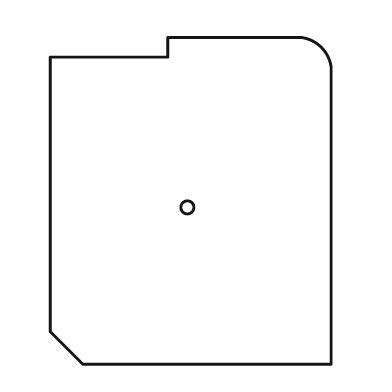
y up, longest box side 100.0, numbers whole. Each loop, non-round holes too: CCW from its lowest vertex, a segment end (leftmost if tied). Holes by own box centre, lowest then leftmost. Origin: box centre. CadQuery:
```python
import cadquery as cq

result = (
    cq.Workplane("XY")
    .moveTo(-33.0, -50.0)
    .lineTo(43.0, -50.0)
    .lineTo(43.0, 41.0)
    .threePointArc((40.0, 47.0), (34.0, 50.0))
    .lineTo(-7.0, 50.0)
    .lineTo(-7.0, 44.0)
    .lineTo(-43.0, 44.0)
    .lineTo(-43.0, -40.0)
    .close()
    .moveTo(-1.0, -2.0)
    .circle(2.0)
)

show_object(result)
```